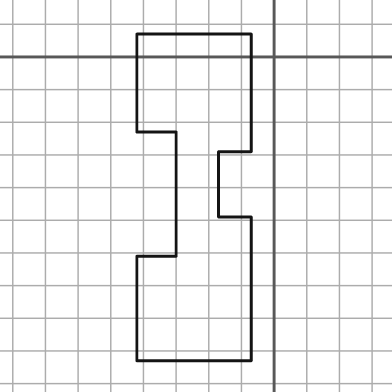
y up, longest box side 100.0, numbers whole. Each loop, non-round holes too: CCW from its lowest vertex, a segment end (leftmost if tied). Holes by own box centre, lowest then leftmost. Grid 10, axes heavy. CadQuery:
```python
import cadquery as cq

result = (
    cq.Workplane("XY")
    .moveTo(-42.0, -93.0)
    .lineTo(-7.0, -93.0)
    .lineTo(-7.0, -49.0)
    .lineTo(-17.0, -49.0)
    .lineTo(-17.0, -29.0)
    .lineTo(-7.0, -29.0)
    .lineTo(-7.0, 7.0)
    .lineTo(-42.0, 7.0)
    .lineTo(-42.0, -23.0)
    .lineTo(-30.0, -23.0)
    .lineTo(-30.0, -61.0)
    .lineTo(-42.0, -61.0)
    .close()
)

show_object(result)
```